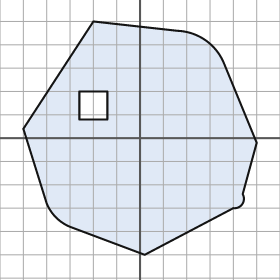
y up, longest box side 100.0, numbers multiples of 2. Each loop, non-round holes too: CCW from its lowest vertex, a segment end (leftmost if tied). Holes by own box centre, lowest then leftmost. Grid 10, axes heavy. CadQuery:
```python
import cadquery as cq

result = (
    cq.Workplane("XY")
    .moveTo(2.0, -50.0)
    .lineTo(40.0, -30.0)
    .threePointArc((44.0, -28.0), (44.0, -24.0))
    .lineTo(50.0, -2.0)
    .lineTo(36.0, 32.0)
    .threePointArc((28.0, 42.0), (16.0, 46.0))
    .lineTo(-20.0, 50.0)
    .lineTo(-50.0, 4.0)
    .lineTo(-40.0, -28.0)
    .threePointArc((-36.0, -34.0), (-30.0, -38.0))
    .close()
    .moveTo(-26.0, 8.0)
    .lineTo(-14.0, 8.0)
    .lineTo(-14.0, 20.0)
    .lineTo(-26.0, 20.0)
    .close()
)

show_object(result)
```